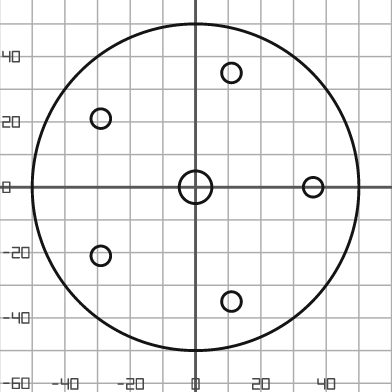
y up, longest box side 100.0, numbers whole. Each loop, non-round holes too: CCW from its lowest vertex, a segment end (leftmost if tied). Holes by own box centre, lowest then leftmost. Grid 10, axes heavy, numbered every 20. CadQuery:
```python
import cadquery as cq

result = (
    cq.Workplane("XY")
    .moveTo(0.0, 0.0)
    .circle(50.0)
    .moveTo(11.0, -35.0)
    .circle(3.0)
    .moveTo(-29.0, -21.0)
    .circle(3.0)
    .moveTo(0.0, 0.0)
    .circle(5.0)
    .moveTo(36.0, 0.0)
    .circle(3.0)
    .moveTo(-29.0, 21.0)
    .circle(3.0)
    .moveTo(11.0, 35.0)
    .circle(3.0)
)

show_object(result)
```